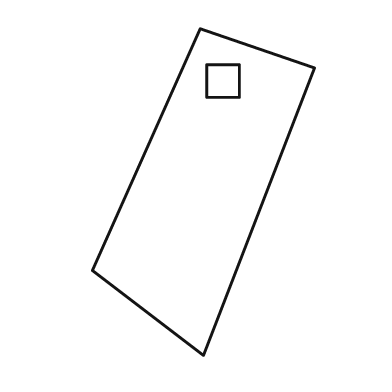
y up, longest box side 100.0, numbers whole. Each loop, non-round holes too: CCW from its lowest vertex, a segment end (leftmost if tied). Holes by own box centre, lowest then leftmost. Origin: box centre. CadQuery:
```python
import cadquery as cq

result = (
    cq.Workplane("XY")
    .moveTo(0.0, -50.0)
    .lineTo(34.0, 38.0)
    .lineTo(-1.0, 50.0)
    .lineTo(-34.0, -24.0)
    .close()
    .moveTo(1.0, 29.0)
    .lineTo(11.0, 29.0)
    .lineTo(11.0, 39.0)
    .lineTo(1.0, 39.0)
    .close()
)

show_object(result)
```